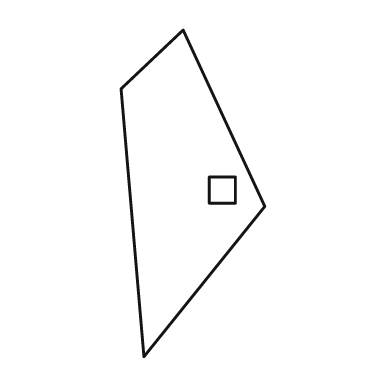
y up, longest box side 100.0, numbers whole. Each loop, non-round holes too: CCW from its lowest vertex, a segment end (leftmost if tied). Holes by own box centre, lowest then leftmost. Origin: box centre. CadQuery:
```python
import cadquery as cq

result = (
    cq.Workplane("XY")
    .moveTo(-15.0, -50.0)
    .lineTo(22.0, -4.0)
    .lineTo(-3.0, 50.0)
    .lineTo(-22.0, 32.0)
    .close()
    .moveTo(5.0, -3.0)
    .lineTo(13.0, -3.0)
    .lineTo(13.0, 5.0)
    .lineTo(5.0, 5.0)
    .close()
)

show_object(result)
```